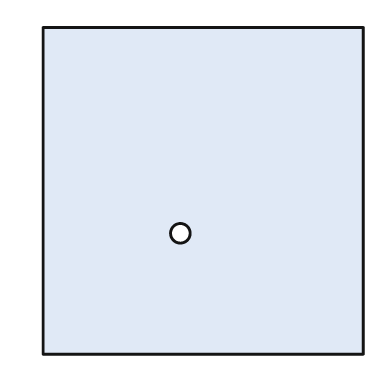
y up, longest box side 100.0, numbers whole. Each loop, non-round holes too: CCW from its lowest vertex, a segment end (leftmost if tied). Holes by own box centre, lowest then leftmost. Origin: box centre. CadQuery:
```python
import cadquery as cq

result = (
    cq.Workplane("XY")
    .moveTo(-49.0, -50.0)
    .lineTo(49.0, -50.0)
    .lineTo(49.0, 50.0)
    .lineTo(-49.0, 50.0)
    .close()
    .moveTo(-7.0, -13.0)
    .circle(3.0)
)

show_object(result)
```